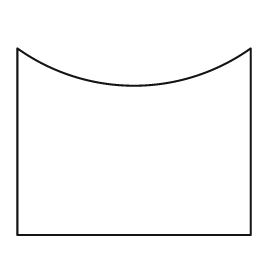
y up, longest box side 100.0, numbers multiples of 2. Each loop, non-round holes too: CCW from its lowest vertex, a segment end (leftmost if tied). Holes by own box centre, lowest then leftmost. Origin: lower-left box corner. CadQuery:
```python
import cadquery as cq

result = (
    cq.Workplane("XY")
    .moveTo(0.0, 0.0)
    .lineTo(100.0, 0.0)
    .lineTo(100.0, 80.0)
    .threePointArc((50.0, 64.0), (0.0, 80.0))
    .close()
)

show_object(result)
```